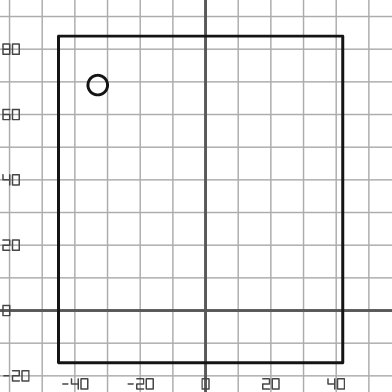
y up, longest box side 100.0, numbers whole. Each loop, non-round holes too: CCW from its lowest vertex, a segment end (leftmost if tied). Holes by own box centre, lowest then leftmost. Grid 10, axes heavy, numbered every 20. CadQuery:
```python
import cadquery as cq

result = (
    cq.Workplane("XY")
    .moveTo(-45.0, -16.0)
    .lineTo(42.0, -16.0)
    .lineTo(42.0, 84.0)
    .lineTo(-45.0, 84.0)
    .close()
    .moveTo(-33.0, 69.0)
    .circle(3.0)
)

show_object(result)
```